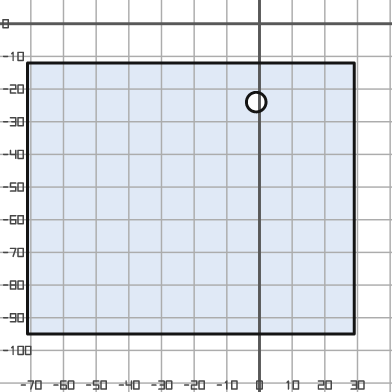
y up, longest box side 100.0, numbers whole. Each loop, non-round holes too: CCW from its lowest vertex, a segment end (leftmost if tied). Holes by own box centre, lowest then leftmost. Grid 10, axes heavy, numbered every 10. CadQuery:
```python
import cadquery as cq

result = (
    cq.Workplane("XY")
    .moveTo(-71.0, -95.0)
    .lineTo(29.0, -95.0)
    .lineTo(29.0, -12.0)
    .lineTo(-71.0, -12.0)
    .close()
    .moveTo(-1.0, -24.0)
    .circle(3.0)
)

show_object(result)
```